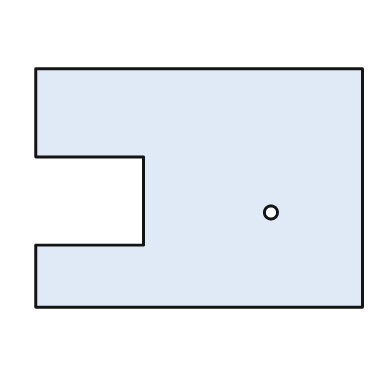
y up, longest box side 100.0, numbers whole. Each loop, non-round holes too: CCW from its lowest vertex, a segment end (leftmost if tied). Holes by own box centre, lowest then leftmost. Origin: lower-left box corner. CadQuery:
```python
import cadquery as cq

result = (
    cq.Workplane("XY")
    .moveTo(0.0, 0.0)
    .lineTo(100.0, 0.0)
    .lineTo(100.0, 73.0)
    .lineTo(0.0, 73.0)
    .lineTo(0.0, 46.0)
    .lineTo(33.0, 46.0)
    .lineTo(33.0, 19.0)
    .lineTo(0.0, 19.0)
    .close()
    .moveTo(72.0, 29.0)
    .circle(2.0)
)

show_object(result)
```